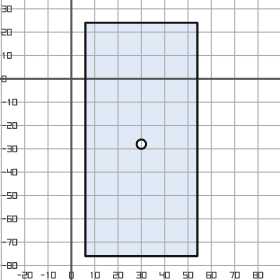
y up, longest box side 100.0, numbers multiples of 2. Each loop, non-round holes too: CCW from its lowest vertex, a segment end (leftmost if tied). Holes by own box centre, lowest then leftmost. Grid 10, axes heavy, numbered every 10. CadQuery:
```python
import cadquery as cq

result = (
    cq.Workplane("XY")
    .moveTo(6.0, -76.0)
    .lineTo(54.0, -76.0)
    .lineTo(54.0, 24.0)
    .lineTo(6.0, 24.0)
    .close()
    .moveTo(30.0, -28.0)
    .circle(2.0)
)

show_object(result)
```